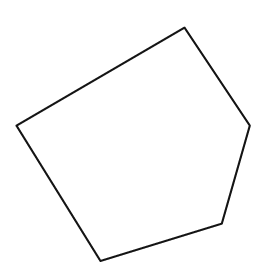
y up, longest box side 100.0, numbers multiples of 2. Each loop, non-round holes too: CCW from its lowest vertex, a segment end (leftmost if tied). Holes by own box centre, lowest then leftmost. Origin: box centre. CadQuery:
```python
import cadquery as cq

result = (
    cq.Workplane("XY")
    .moveTo(-14.0, -50.0)
    .lineTo(38.0, -34.0)
    .lineTo(50.0, 8.0)
    .lineTo(22.0, 50.0)
    .lineTo(-50.0, 8.0)
    .close()
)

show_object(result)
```